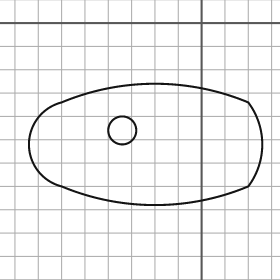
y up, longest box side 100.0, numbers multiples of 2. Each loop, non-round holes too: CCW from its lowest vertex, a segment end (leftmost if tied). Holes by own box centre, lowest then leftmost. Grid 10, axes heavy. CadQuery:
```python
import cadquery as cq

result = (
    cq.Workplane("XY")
    .moveTo(-60.0, -70.0)
    .threePointArc((-20.0, -78.0), (20.0, -70.0))
    .threePointArc((26.0, -52.0), (20.0, -34.0))
    .threePointArc((-20.0, -26.0), (-60.0, -34.0))
    .threePointArc((-74.0, -52.0), (-60.0, -70.0))
    .close()
    .moveTo(-34.0, -46.0)
    .circle(6.0)
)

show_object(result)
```